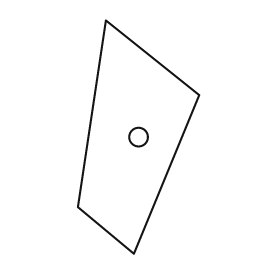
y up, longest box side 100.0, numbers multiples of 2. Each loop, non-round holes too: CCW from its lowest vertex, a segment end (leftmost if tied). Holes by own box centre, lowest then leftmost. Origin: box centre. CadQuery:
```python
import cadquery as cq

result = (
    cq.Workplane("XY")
    .moveTo(-2.0, -50.0)
    .lineTo(26.0, 18.0)
    .lineTo(-14.0, 50.0)
    .lineTo(-26.0, -30.0)
    .close()
    .moveTo(0.0, 0.0)
    .circle(4.0)
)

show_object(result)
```